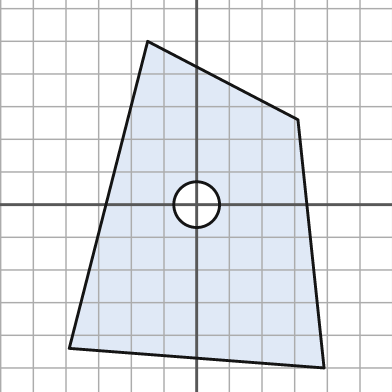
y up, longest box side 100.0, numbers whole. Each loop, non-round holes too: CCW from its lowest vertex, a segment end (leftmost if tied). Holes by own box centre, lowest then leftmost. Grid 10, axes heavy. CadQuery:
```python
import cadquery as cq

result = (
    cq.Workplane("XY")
    .moveTo(39.0, -50.0)
    .lineTo(31.0, 26.0)
    .lineTo(-15.0, 50.0)
    .lineTo(-39.0, -44.0)
    .close()
    .moveTo(0.0, 0.0)
    .circle(7.0)
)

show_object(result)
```